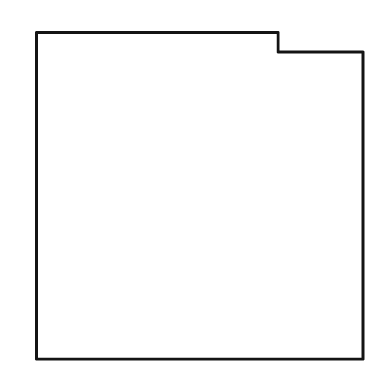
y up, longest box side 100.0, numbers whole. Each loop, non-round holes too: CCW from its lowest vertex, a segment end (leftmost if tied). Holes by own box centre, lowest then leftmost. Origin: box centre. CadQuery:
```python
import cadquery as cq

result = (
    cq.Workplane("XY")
    .moveTo(-50.0, -50.0)
    .lineTo(50.0, -50.0)
    .lineTo(50.0, 44.0)
    .lineTo(24.0, 44.0)
    .lineTo(24.0, 50.0)
    .lineTo(-50.0, 50.0)
    .close()
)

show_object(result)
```